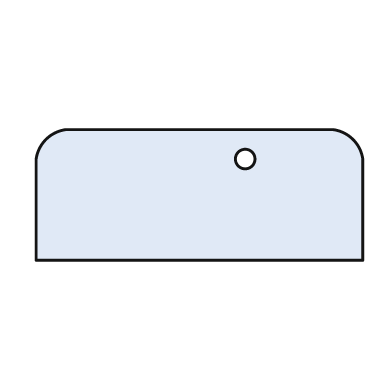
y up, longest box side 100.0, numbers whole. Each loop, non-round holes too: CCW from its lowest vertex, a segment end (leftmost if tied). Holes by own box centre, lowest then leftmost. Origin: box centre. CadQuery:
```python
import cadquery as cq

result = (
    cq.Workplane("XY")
    .moveTo(-50.0, -20.0)
    .lineTo(50.0, -20.0)
    .lineTo(50.0, 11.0)
    .threePointArc((47.0, 17.0), (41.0, 20.0))
    .lineTo(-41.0, 20.0)
    .threePointArc((-47.0, 17.0), (-50.0, 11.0))
    .close()
    .moveTo(14.0, 11.0)
    .circle(3.0)
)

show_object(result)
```